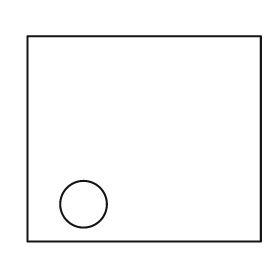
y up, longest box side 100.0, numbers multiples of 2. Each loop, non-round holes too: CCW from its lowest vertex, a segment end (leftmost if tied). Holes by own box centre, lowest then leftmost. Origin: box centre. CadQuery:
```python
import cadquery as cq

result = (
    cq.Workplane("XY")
    .moveTo(-50.0, -44.0)
    .lineTo(50.0, -44.0)
    .lineTo(50.0, 44.0)
    .lineTo(-50.0, 44.0)
    .close()
    .moveTo(-26.0, -28.0)
    .circle(10.0)
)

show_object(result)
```